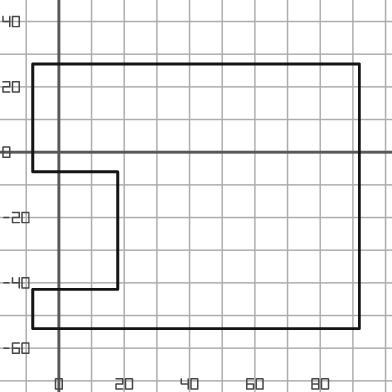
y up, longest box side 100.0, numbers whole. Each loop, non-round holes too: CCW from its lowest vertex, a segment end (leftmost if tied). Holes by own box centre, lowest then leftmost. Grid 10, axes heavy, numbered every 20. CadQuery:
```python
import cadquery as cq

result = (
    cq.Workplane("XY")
    .moveTo(-8.0, -54.0)
    .lineTo(92.0, -54.0)
    .lineTo(92.0, 27.0)
    .lineTo(-8.0, 27.0)
    .lineTo(-8.0, -6.0)
    .lineTo(18.0, -6.0)
    .lineTo(18.0, -42.0)
    .lineTo(-8.0, -42.0)
    .close()
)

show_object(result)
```